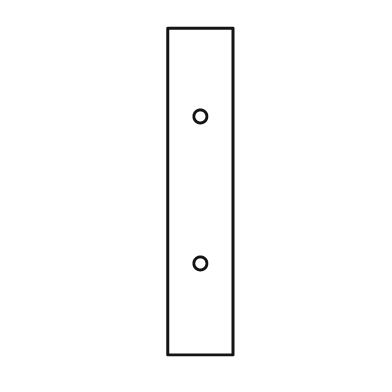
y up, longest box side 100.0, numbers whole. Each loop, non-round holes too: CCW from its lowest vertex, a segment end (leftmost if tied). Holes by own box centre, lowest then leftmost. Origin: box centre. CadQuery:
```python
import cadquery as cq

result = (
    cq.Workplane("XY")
    .moveTo(-10.0, -50.0)
    .lineTo(10.0, -50.0)
    .lineTo(10.0, 50.0)
    .lineTo(-10.0, 50.0)
    .close()
    .moveTo(0.0, -22.0)
    .circle(2.0)
    .moveTo(0.0, 23.0)
    .circle(2.0)
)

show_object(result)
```